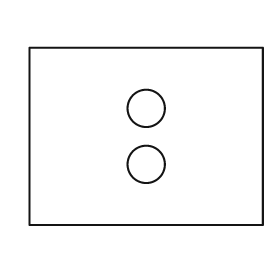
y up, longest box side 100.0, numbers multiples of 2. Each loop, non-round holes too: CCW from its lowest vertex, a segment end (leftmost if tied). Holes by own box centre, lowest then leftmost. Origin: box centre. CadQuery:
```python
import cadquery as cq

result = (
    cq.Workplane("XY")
    .moveTo(-50.0, -38.0)
    .lineTo(50.0, -38.0)
    .lineTo(50.0, 38.0)
    .lineTo(-50.0, 38.0)
    .close()
    .moveTo(0.0, -12.0)
    .circle(8.0)
    .moveTo(0.0, 12.0)
    .circle(8.0)
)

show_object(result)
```